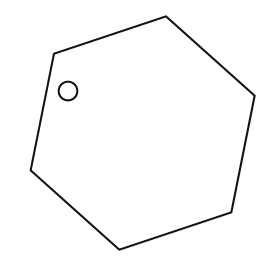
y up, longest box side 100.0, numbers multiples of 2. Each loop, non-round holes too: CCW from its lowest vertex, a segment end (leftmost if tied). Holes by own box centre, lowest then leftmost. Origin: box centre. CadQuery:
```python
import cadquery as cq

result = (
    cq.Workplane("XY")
    .moveTo(-10.0, -50.0)
    .lineTo(38.0, -34.0)
    .lineTo(48.0, 16.0)
    .lineTo(10.0, 50.0)
    .lineTo(-38.0, 34.0)
    .lineTo(-48.0, -16.0)
    .close()
    .moveTo(-32.0, 18.0)
    .circle(4.0)
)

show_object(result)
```